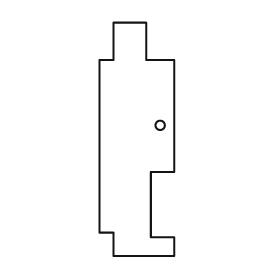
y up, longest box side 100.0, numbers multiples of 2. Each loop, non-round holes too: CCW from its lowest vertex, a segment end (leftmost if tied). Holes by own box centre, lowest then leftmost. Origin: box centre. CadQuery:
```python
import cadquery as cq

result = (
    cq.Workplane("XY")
    .moveTo(-10.0, -50.0)
    .lineTo(16.0, -50.0)
    .lineTo(16.0, -42.0)
    .lineTo(6.0, -42.0)
    .lineTo(6.0, -14.0)
    .lineTo(16.0, -14.0)
    .lineTo(16.0, 34.0)
    .lineTo(4.0, 34.0)
    .lineTo(4.0, 50.0)
    .lineTo(-10.0, 50.0)
    .lineTo(-10.0, 34.0)
    .lineTo(-16.0, 34.0)
    .lineTo(-16.0, -40.0)
    .lineTo(-10.0, -40.0)
    .close()
    .moveTo(10.0, 6.0)
    .circle(2.0)
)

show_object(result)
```